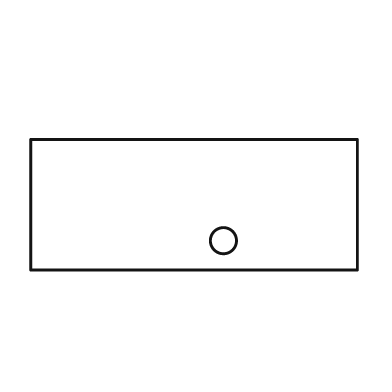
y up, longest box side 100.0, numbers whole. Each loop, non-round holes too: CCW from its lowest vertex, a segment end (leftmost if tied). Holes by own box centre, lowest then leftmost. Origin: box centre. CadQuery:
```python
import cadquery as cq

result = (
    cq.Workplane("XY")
    .moveTo(-50.0, -20.0)
    .lineTo(50.0, -20.0)
    .lineTo(50.0, 20.0)
    .lineTo(-50.0, 20.0)
    .close()
    .moveTo(9.0, -11.0)
    .circle(4.0)
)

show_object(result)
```